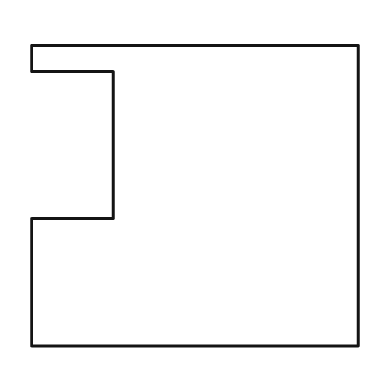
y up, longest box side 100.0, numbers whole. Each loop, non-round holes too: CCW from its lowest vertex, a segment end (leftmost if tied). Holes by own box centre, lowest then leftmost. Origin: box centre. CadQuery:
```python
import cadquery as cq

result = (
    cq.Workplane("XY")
    .moveTo(-50.0, -46.0)
    .lineTo(50.0, -46.0)
    .lineTo(50.0, 46.0)
    .lineTo(-50.0, 46.0)
    .lineTo(-50.0, 38.0)
    .lineTo(-25.0, 38.0)
    .lineTo(-25.0, -7.0)
    .lineTo(-50.0, -7.0)
    .close()
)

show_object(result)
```